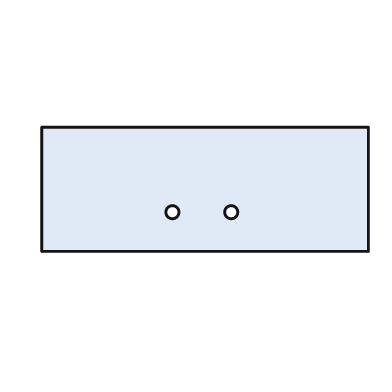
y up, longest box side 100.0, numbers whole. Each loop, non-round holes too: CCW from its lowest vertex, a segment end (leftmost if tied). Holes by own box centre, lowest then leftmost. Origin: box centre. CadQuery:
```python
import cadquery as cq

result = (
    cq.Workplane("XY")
    .moveTo(-50.0, -19.0)
    .lineTo(50.0, -19.0)
    .lineTo(50.0, 19.0)
    .lineTo(-50.0, 19.0)
    .close()
    .moveTo(-10.0, -7.0)
    .circle(2.0)
    .moveTo(8.0, -7.0)
    .circle(2.0)
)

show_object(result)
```